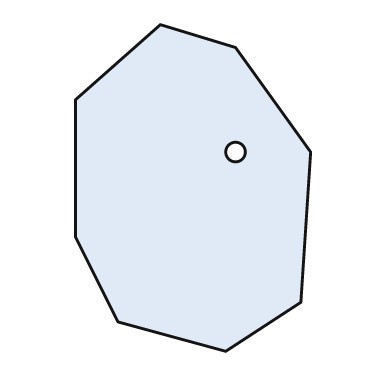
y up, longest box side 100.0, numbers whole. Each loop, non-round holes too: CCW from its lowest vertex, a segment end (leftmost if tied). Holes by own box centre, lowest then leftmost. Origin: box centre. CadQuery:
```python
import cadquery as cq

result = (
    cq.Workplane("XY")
    .moveTo(10.0, -50.0)
    .lineTo(33.0, -35.0)
    .lineTo(36.0, 11.0)
    .lineTo(13.0, 43.0)
    .lineTo(-10.0, 50.0)
    .lineTo(-36.0, 27.0)
    .lineTo(-36.0, -15.0)
    .lineTo(-23.0, -41.0)
    .close()
    .moveTo(13.0, 11.0)
    .circle(3.0)
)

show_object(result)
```